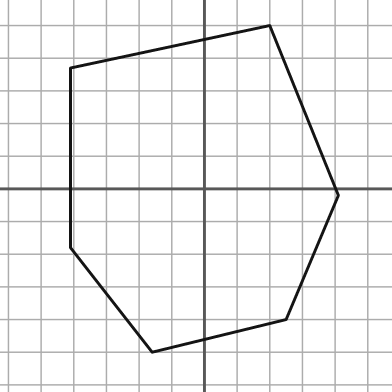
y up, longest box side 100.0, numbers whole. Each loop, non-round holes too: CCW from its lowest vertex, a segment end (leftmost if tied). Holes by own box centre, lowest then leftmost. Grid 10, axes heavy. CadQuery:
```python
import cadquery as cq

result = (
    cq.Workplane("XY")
    .moveTo(-16.0, -50.0)
    .lineTo(25.0, -40.0)
    .lineTo(41.0, -2.0)
    .lineTo(20.0, 50.0)
    .lineTo(-41.0, 37.0)
    .lineTo(-41.0, -18.0)
    .close()
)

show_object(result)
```